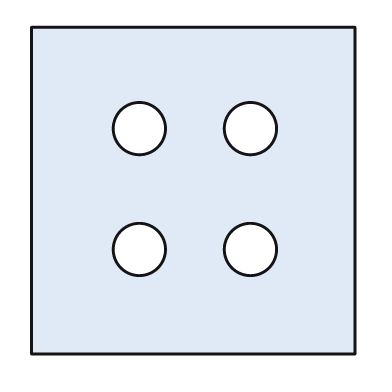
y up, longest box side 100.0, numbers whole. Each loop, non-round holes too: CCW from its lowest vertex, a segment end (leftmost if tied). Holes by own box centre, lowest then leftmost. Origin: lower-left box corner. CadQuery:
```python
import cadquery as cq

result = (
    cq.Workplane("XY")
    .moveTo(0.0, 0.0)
    .lineTo(99.0, 0.0)
    .lineTo(99.0, 100.0)
    .lineTo(0.0, 100.0)
    .close()
    .moveTo(33.0, 32.0)
    .circle(8.0)
    .moveTo(67.0, 32.0)
    .circle(8.0)
    .moveTo(33.0, 69.0)
    .circle(8.0)
    .moveTo(67.0, 69.0)
    .circle(8.0)
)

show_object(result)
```